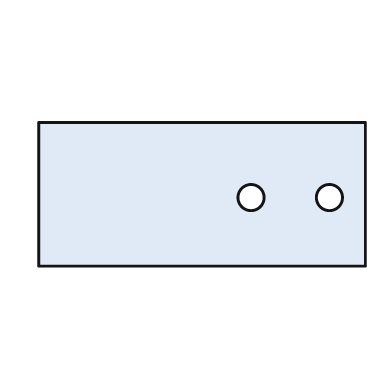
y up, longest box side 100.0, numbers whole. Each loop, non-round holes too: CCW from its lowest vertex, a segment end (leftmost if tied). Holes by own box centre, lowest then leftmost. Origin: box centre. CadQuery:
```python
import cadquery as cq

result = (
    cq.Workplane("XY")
    .moveTo(-50.0, -22.0)
    .lineTo(50.0, -22.0)
    .lineTo(50.0, 22.0)
    .lineTo(-50.0, 22.0)
    .close()
    .moveTo(15.0, -1.0)
    .circle(4.0)
    .moveTo(39.0, -1.0)
    .circle(4.0)
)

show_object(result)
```